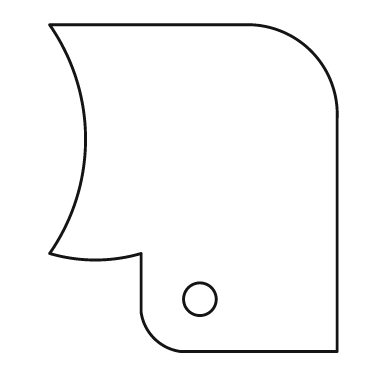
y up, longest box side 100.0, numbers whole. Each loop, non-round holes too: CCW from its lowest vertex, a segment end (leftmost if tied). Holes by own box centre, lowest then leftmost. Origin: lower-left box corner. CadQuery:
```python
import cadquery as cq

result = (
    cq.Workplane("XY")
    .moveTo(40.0, 0.0)
    .lineTo(88.0, 0.0)
    .lineTo(88.0, 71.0)
    .threePointArc((80.0, 92.0), (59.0, 100.0))
    .lineTo(0.0, 100.0)
    .threePointArc((11.0, 65.0), (0.0, 30.0))
    .threePointArc((14.0, 28.0), (28.0, 30.0))
    .lineTo(28.0, 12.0)
    .threePointArc((32.0, 4.0), (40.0, 0.0))
    .close()
    .moveTo(46.0, 16.0)
    .circle(5.0)
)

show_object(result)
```